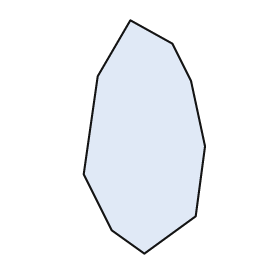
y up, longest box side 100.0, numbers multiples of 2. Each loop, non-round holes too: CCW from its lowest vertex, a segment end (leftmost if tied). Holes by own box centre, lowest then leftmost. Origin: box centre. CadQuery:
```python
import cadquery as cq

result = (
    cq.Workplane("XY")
    .moveTo(0.0, -50.0)
    .lineTo(22.0, -34.0)
    .lineTo(26.0, -4.0)
    .lineTo(20.0, 24.0)
    .lineTo(12.0, 40.0)
    .lineTo(-6.0, 50.0)
    .lineTo(-20.0, 26.0)
    .lineTo(-26.0, -16.0)
    .lineTo(-14.0, -40.0)
    .close()
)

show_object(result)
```